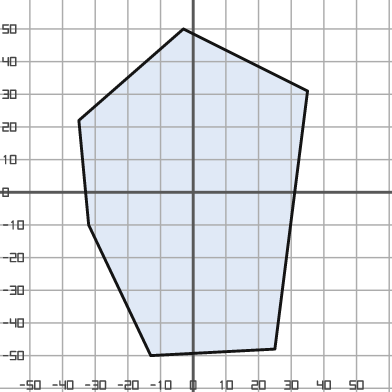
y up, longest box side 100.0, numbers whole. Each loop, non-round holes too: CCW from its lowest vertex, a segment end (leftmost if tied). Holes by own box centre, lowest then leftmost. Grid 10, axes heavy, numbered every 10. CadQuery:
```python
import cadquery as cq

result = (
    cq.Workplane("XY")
    .moveTo(-13.0, -50.0)
    .lineTo(25.0, -48.0)
    .lineTo(35.0, 31.0)
    .lineTo(-3.0, 50.0)
    .lineTo(-35.0, 22.0)
    .lineTo(-32.0, -10.0)
    .close()
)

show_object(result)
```